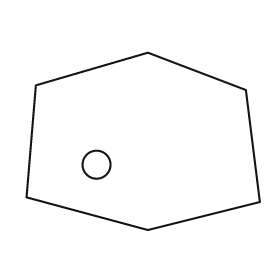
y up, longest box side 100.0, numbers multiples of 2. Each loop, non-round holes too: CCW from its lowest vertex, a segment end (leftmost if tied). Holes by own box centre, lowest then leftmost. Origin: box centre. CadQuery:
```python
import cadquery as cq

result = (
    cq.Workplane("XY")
    .moveTo(2.0, -38.0)
    .lineTo(50.0, -26.0)
    .lineTo(44.0, 22.0)
    .lineTo(2.0, 38.0)
    .lineTo(-46.0, 24.0)
    .lineTo(-50.0, -24.0)
    .close()
    .moveTo(-20.0, -10.0)
    .circle(6.0)
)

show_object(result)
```